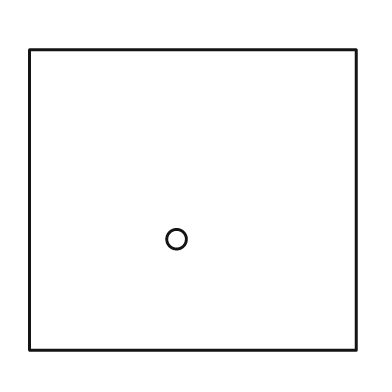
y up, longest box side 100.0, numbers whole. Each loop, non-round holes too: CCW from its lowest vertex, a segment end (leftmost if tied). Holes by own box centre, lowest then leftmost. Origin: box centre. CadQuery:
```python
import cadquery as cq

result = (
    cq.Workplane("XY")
    .moveTo(-50.0, -46.0)
    .lineTo(50.0, -46.0)
    .lineTo(50.0, 46.0)
    .lineTo(-50.0, 46.0)
    .close()
    .moveTo(-5.0, -12.0)
    .circle(3.0)
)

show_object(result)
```